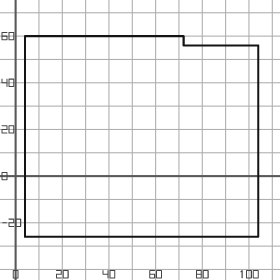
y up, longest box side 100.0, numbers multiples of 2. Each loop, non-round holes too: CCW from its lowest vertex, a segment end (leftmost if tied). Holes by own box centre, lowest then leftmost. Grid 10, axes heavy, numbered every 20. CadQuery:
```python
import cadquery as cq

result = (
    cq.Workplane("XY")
    .moveTo(4.0, -26.0)
    .lineTo(104.0, -26.0)
    .lineTo(104.0, 56.0)
    .lineTo(72.0, 56.0)
    .lineTo(72.0, 60.0)
    .lineTo(4.0, 60.0)
    .close()
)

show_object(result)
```